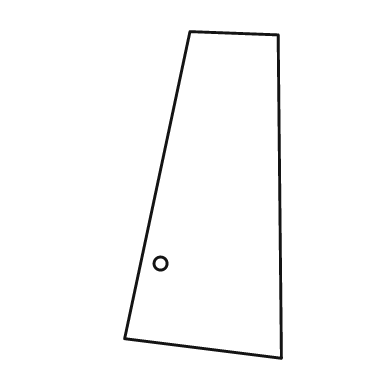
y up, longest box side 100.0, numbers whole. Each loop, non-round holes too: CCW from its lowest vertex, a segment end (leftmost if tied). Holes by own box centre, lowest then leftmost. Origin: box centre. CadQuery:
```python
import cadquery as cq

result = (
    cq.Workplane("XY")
    .moveTo(24.0, -50.0)
    .lineTo(23.0, 49.0)
    .lineTo(-4.0, 50.0)
    .lineTo(-24.0, -44.0)
    .close()
    .moveTo(-13.0, -21.0)
    .circle(2.0)
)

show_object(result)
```